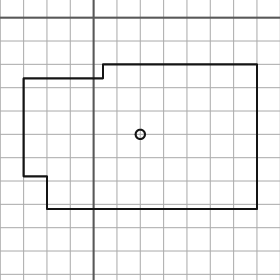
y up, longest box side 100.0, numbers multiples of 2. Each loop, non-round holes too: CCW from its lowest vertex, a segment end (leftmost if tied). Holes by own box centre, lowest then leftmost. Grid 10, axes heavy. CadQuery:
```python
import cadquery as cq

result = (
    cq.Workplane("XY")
    .moveTo(-20.0, -82.0)
    .lineTo(70.0, -82.0)
    .lineTo(70.0, -20.0)
    .lineTo(4.0, -20.0)
    .lineTo(4.0, -26.0)
    .lineTo(-30.0, -26.0)
    .lineTo(-30.0, -68.0)
    .lineTo(-20.0, -68.0)
    .close()
    .moveTo(20.0, -50.0)
    .circle(2.0)
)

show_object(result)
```